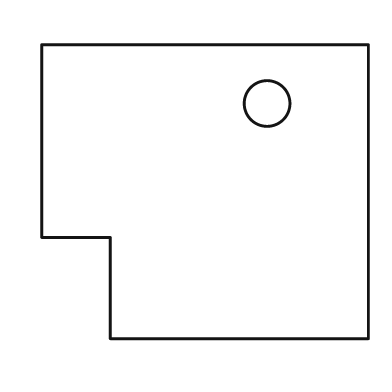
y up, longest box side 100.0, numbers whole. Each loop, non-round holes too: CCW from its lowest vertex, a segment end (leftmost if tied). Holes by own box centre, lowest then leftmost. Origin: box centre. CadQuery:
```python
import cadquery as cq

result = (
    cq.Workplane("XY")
    .moveTo(-29.0, -45.0)
    .lineTo(50.0, -45.0)
    .lineTo(50.0, 45.0)
    .lineTo(-50.0, 45.0)
    .lineTo(-50.0, -14.0)
    .lineTo(-29.0, -14.0)
    .close()
    .moveTo(19.0, 27.0)
    .circle(7.0)
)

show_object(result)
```